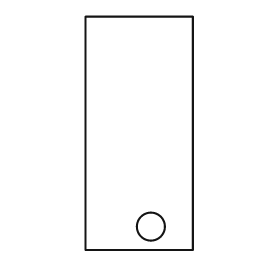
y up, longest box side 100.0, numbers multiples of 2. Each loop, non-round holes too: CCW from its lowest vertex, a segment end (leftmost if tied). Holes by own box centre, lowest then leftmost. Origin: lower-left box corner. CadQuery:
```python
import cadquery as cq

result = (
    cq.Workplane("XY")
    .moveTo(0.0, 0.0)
    .lineTo(46.0, 0.0)
    .lineTo(46.0, 100.0)
    .lineTo(0.0, 100.0)
    .close()
    .moveTo(28.0, 10.0)
    .circle(6.0)
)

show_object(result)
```